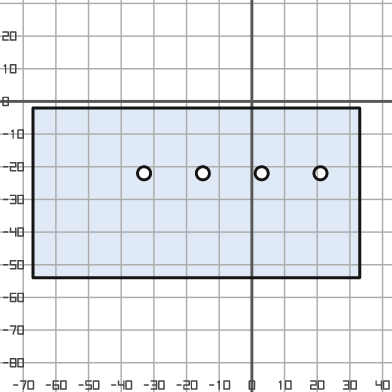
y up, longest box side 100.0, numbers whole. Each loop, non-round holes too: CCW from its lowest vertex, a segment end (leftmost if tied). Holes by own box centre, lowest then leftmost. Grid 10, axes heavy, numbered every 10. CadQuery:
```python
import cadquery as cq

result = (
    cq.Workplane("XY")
    .moveTo(-67.0, -54.0)
    .lineTo(33.0, -54.0)
    .lineTo(33.0, -2.0)
    .lineTo(-67.0, -2.0)
    .close()
    .moveTo(-33.0, -22.0)
    .circle(2.0)
    .moveTo(-15.0, -22.0)
    .circle(2.0)
    .moveTo(3.0, -22.0)
    .circle(2.0)
    .moveTo(21.0, -22.0)
    .circle(2.0)
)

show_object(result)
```